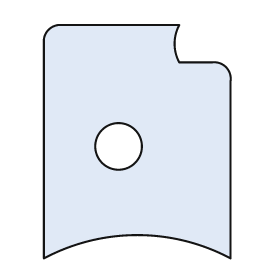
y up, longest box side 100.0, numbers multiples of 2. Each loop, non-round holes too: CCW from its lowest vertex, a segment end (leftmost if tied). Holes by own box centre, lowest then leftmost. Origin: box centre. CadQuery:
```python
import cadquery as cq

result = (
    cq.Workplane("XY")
    .moveTo(-40.0, -50.0)
    .threePointArc((0.0, -40.0), (40.0, -50.0))
    .lineTo(40.0, 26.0)
    .threePointArc((38.0, 32.0), (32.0, 34.0))
    .lineTo(18.0, 34.0)
    .threePointArc((16.0, 42.0), (18.0, 50.0))
    .lineTo(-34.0, 50.0)
    .threePointArc((-38.0, 48.0), (-40.0, 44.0))
    .close()
    .moveTo(-8.0, -2.0)
    .circle(10.0)
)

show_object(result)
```